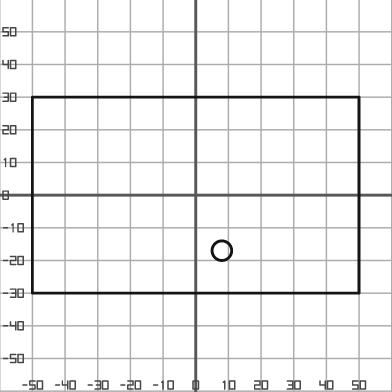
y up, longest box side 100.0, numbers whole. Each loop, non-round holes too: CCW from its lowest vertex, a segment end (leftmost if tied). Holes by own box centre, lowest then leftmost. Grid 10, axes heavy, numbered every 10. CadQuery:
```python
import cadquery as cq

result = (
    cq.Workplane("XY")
    .moveTo(-50.0, -30.0)
    .lineTo(50.0, -30.0)
    .lineTo(50.0, 30.0)
    .lineTo(-50.0, 30.0)
    .close()
    .moveTo(8.0, -17.0)
    .circle(3.0)
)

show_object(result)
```